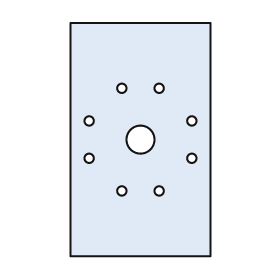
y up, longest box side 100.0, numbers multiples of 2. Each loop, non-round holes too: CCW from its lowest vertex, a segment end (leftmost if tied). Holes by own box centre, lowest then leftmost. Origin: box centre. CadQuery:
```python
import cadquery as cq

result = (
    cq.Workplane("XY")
    .moveTo(-30.0, -50.0)
    .lineTo(30.0, -50.0)
    .lineTo(30.0, 50.0)
    .lineTo(-30.0, 50.0)
    .close()
    .moveTo(-8.0, -22.0)
    .circle(2.0)
    .moveTo(8.0, -22.0)
    .circle(2.0)
    .moveTo(-22.0, -8.0)
    .circle(2.0)
    .moveTo(22.0, -8.0)
    .circle(2.0)
    .moveTo(0.0, 0.0)
    .circle(6.0)
    .moveTo(-22.0, 8.0)
    .circle(2.0)
    .moveTo(22.0, 8.0)
    .circle(2.0)
    .moveTo(-8.0, 22.0)
    .circle(2.0)
    .moveTo(8.0, 22.0)
    .circle(2.0)
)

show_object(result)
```